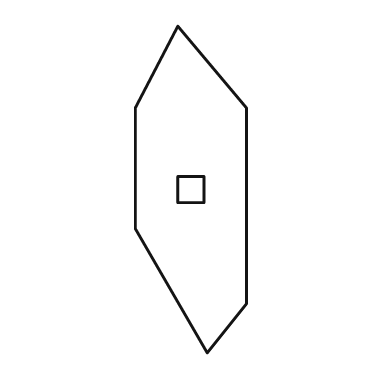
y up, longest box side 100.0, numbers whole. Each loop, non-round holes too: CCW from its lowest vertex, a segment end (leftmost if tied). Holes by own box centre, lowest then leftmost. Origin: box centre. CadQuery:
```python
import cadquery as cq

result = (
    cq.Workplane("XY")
    .moveTo(5.0, -50.0)
    .lineTo(17.0, -35.0)
    .lineTo(17.0, 25.0)
    .lineTo(-4.0, 50.0)
    .lineTo(-17.0, 25.0)
    .lineTo(-17.0, -12.0)
    .close()
    .moveTo(-4.0, -4.0)
    .lineTo(4.0, -4.0)
    .lineTo(4.0, 4.0)
    .lineTo(-4.0, 4.0)
    .close()
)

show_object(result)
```